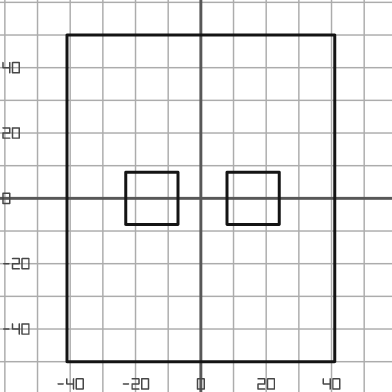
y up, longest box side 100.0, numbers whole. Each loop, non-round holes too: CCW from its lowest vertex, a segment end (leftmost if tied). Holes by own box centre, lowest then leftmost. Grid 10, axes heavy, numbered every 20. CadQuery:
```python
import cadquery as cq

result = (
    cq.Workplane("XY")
    .moveTo(-41.0, -50.0)
    .lineTo(41.0, -50.0)
    .lineTo(41.0, 50.0)
    .lineTo(-41.0, 50.0)
    .close()
    .moveTo(-23.0, -8.0)
    .lineTo(-7.0, -8.0)
    .lineTo(-7.0, 8.0)
    .lineTo(-23.0, 8.0)
    .close()
    .moveTo(8.0, -8.0)
    .lineTo(24.0, -8.0)
    .lineTo(24.0, 8.0)
    .lineTo(8.0, 8.0)
    .close()
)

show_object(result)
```